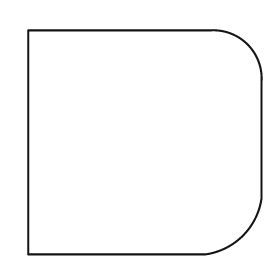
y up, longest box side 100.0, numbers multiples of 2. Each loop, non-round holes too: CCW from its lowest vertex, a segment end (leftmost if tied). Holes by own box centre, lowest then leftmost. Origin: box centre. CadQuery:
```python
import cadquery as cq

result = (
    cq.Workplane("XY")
    .moveTo(-50.0, -48.0)
    .lineTo(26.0, -48.0)
    .threePointArc((42.0, -40.0), (50.0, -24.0))
    .lineTo(50.0, 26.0)
    .threePointArc((44.0, 42.0), (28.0, 48.0))
    .lineTo(-50.0, 48.0)
    .close()
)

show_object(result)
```